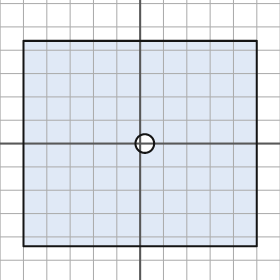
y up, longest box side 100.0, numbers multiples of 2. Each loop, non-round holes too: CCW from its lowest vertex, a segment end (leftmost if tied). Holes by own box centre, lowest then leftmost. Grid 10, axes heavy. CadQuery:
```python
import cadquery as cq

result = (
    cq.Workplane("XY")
    .moveTo(-50.0, -44.0)
    .lineTo(50.0, -44.0)
    .lineTo(50.0, 44.0)
    .lineTo(-50.0, 44.0)
    .close()
    .moveTo(2.0, 0.0)
    .circle(4.0)
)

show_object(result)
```